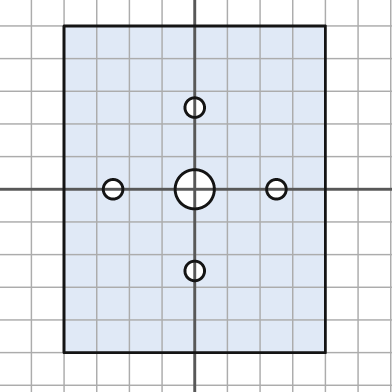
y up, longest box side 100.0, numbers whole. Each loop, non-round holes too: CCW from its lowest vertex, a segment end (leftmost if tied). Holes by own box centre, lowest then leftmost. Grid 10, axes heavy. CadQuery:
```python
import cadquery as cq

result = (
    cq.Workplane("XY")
    .moveTo(-40.0, -50.0)
    .lineTo(40.0, -50.0)
    .lineTo(40.0, 50.0)
    .lineTo(-40.0, 50.0)
    .close()
    .moveTo(0.0, -25.0)
    .circle(3.0)
    .moveTo(-25.0, 0.0)
    .circle(3.0)
    .moveTo(0.0, 0.0)
    .circle(6.0)
    .moveTo(25.0, 0.0)
    .circle(3.0)
    .moveTo(0.0, 25.0)
    .circle(3.0)
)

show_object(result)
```